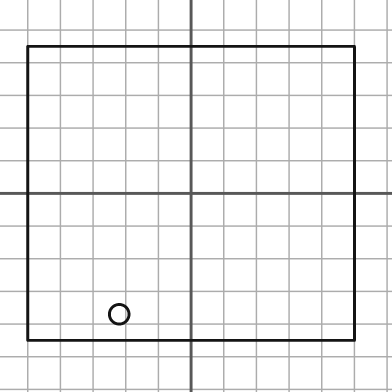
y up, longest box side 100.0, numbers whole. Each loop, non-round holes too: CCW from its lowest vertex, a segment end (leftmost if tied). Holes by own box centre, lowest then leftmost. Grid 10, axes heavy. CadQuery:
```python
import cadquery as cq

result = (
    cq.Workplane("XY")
    .moveTo(-50.0, -45.0)
    .lineTo(50.0, -45.0)
    .lineTo(50.0, 45.0)
    .lineTo(-50.0, 45.0)
    .close()
    .moveTo(-22.0, -37.0)
    .circle(3.0)
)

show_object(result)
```